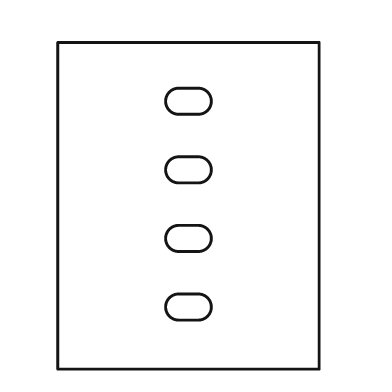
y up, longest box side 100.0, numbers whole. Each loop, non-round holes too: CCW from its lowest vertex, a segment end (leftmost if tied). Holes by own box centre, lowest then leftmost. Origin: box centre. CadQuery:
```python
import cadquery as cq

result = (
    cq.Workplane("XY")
    .moveTo(-40.0, -50.0)
    .lineTo(40.0, -50.0)
    .lineTo(40.0, 50.0)
    .lineTo(-40.0, 50.0)
    .close()
    .moveTo(-3.0, -35.0)
    .lineTo(3.0, -35.0)
    .threePointArc((7.0, -31.0), (3.0, -27.0))
    .lineTo(-3.0, -27.0)
    .threePointArc((-7.0, -31.0), (-3.0, -35.0))
    .close()
    .moveTo(-3.0, -14.0)
    .lineTo(3.0, -14.0)
    .threePointArc((7.0, -10.0), (3.0, -6.0))
    .lineTo(-3.0, -6.0)
    .threePointArc((-7.0, -10.0), (-3.0, -14.0))
    .close()
    .moveTo(-3.0, 7.0)
    .lineTo(3.0, 7.0)
    .threePointArc((7.0, 11.0), (3.0, 15.0))
    .lineTo(-3.0, 15.0)
    .threePointArc((-7.0, 11.0), (-3.0, 7.0))
    .close()
    .moveTo(-3.0, 28.0)
    .lineTo(3.0, 28.0)
    .threePointArc((7.0, 32.0), (3.0, 36.0))
    .lineTo(-3.0, 36.0)
    .threePointArc((-7.0, 32.0), (-3.0, 28.0))
    .close()
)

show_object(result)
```